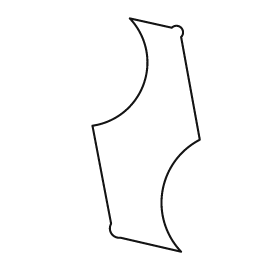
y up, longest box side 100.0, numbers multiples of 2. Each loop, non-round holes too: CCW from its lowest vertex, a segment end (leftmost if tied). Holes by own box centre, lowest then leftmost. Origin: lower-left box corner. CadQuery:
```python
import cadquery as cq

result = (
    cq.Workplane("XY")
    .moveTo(38.0, 0.0)
    .threePointArc((30.0, 26.0), (46.0, 48.0))
    .lineTo(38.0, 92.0)
    .threePointArc((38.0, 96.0), (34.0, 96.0))
    .lineTo(16.0, 100.0)
    .threePointArc((22.0, 72.0), (0.0, 54.0))
    .lineTo(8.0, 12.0)
    .threePointArc((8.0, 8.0), (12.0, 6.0))
    .close()
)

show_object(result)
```